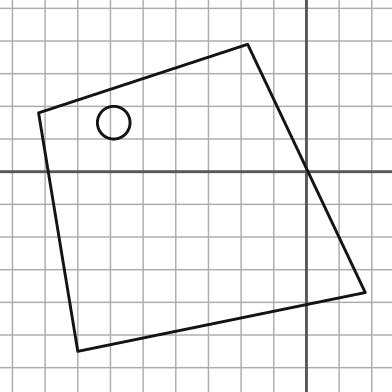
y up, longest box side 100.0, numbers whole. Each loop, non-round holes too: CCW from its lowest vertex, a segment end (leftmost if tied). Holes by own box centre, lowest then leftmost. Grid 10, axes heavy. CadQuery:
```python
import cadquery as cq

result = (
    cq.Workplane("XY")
    .moveTo(-70.0, -55.0)
    .lineTo(18.0, -37.0)
    .lineTo(-18.0, 39.0)
    .lineTo(-82.0, 18.0)
    .close()
    .moveTo(-59.0, 15.0)
    .circle(5.0)
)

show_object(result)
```